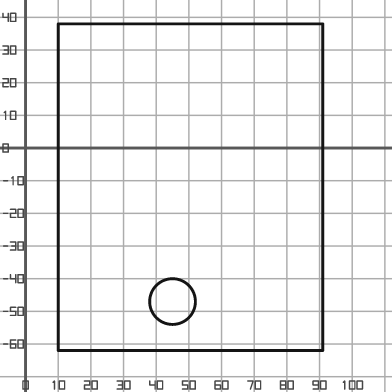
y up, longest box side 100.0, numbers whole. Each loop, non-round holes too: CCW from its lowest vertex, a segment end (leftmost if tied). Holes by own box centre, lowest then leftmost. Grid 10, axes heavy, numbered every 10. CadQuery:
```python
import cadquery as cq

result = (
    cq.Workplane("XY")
    .moveTo(10.0, -62.0)
    .lineTo(91.0, -62.0)
    .lineTo(91.0, 38.0)
    .lineTo(10.0, 38.0)
    .close()
    .moveTo(45.0, -47.0)
    .circle(7.0)
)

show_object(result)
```